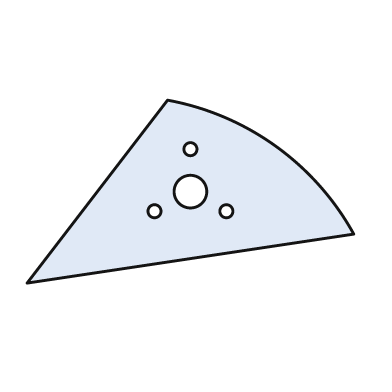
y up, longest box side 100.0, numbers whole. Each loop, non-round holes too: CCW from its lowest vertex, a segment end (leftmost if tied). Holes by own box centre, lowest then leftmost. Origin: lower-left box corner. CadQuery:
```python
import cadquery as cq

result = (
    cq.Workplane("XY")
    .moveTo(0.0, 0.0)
    .lineTo(100.0, 15.0)
    .threePointArc((76.0, 42.0), (43.0, 56.0))
    .close()
    .moveTo(39.0, 22.0)
    .circle(2.0)
    .moveTo(61.0, 22.0)
    .circle(2.0)
    .moveTo(50.0, 28.0)
    .circle(5.0)
    .moveTo(50.0, 41.0)
    .circle(2.0)
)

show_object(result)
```